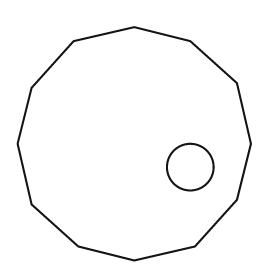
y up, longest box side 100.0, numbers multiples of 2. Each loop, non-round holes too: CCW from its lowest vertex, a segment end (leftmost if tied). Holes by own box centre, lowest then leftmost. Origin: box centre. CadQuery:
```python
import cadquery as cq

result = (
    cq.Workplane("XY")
    .moveTo(0.0, -50.0)
    .lineTo(26.0, -44.0)
    .lineTo(44.0, -24.0)
    .lineTo(50.0, 0.0)
    .lineTo(44.0, 26.0)
    .lineTo(24.0, 44.0)
    .lineTo(0.0, 50.0)
    .lineTo(-26.0, 44.0)
    .lineTo(-44.0, 24.0)
    .lineTo(-50.0, 0.0)
    .lineTo(-44.0, -26.0)
    .lineTo(-24.0, -44.0)
    .close()
    .moveTo(24.0, -10.0)
    .circle(10.0)
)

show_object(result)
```